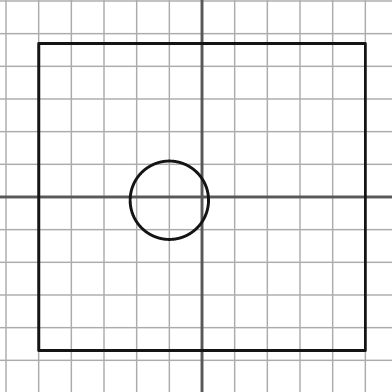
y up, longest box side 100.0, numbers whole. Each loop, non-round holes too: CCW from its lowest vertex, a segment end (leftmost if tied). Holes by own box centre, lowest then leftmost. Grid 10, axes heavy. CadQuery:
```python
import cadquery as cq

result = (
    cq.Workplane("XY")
    .moveTo(-50.0, -47.0)
    .lineTo(50.0, -47.0)
    .lineTo(50.0, 47.0)
    .lineTo(-50.0, 47.0)
    .close()
    .moveTo(-10.0, -1.0)
    .circle(12.0)
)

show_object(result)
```